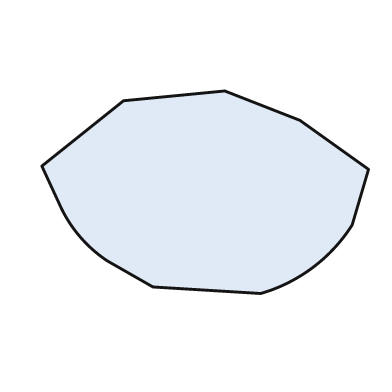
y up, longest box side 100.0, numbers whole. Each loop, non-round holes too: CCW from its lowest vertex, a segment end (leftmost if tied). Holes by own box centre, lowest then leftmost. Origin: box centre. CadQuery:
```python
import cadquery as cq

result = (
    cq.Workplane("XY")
    .moveTo(17.0, -31.0)
    .threePointArc((33.0, -23.0), (45.0, -10.0))
    .lineTo(50.0, 7.0)
    .lineTo(29.0, 22.0)
    .lineTo(6.0, 31.0)
    .lineTo(-25.0, 28.0)
    .lineTo(-50.0, 8.0)
    .lineTo(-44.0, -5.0)
    .threePointArc((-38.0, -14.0), (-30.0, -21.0))
    .lineTo(-16.0, -29.0)
    .close()
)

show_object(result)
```